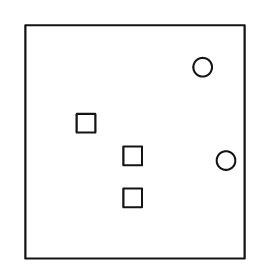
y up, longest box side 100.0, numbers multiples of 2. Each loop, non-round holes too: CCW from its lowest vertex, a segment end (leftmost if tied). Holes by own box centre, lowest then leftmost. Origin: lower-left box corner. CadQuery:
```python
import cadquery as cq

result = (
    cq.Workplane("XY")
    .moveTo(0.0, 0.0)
    .lineTo(94.0, 0.0)
    .lineTo(94.0, 100.0)
    .lineTo(0.0, 100.0)
    .close()
    .moveTo(42.0, 22.0)
    .lineTo(50.0, 22.0)
    .lineTo(50.0, 30.0)
    .lineTo(42.0, 30.0)
    .close()
    .moveTo(86.0, 42.0)
    .circle(4.0)
    .moveTo(42.0, 40.0)
    .lineTo(50.0, 40.0)
    .lineTo(50.0, 48.0)
    .lineTo(42.0, 48.0)
    .close()
    .moveTo(22.0, 54.0)
    .lineTo(30.0, 54.0)
    .lineTo(30.0, 62.0)
    .lineTo(22.0, 62.0)
    .close()
    .moveTo(76.0, 82.0)
    .circle(4.0)
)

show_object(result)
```